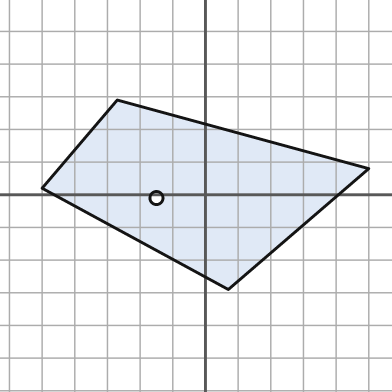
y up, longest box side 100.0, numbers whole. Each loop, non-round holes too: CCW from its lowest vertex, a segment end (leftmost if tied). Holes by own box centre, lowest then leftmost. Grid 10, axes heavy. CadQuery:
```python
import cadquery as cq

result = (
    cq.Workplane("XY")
    .moveTo(7.0, -29.0)
    .lineTo(50.0, 8.0)
    .lineTo(-27.0, 29.0)
    .lineTo(-50.0, 2.0)
    .close()
    .moveTo(-15.0, -1.0)
    .circle(2.0)
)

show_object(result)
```